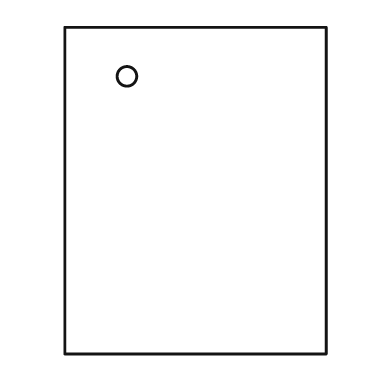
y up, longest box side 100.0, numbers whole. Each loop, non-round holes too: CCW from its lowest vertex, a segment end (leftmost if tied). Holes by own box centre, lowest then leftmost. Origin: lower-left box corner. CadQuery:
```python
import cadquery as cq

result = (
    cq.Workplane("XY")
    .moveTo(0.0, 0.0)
    .lineTo(80.0, 0.0)
    .lineTo(80.0, 100.0)
    .lineTo(0.0, 100.0)
    .close()
    .moveTo(19.0, 85.0)
    .circle(3.0)
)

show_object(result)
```